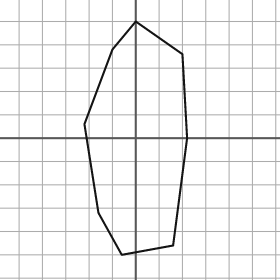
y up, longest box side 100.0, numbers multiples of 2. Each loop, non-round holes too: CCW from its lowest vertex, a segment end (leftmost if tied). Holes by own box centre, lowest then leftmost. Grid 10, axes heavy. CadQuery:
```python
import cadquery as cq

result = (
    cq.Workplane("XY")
    .moveTo(-6.0, -50.0)
    .lineTo(16.0, -46.0)
    .lineTo(22.0, 0.0)
    .lineTo(20.0, 36.0)
    .lineTo(0.0, 50.0)
    .lineTo(-10.0, 38.0)
    .lineTo(-22.0, 6.0)
    .lineTo(-16.0, -32.0)
    .close()
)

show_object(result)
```